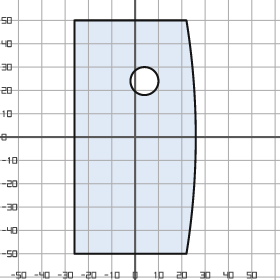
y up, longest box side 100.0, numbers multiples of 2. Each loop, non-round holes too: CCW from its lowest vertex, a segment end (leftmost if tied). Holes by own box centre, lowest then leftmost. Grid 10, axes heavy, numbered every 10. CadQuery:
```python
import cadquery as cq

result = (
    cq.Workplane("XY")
    .moveTo(-26.0, -50.0)
    .lineTo(22.0, -50.0)
    .threePointArc((26.0, 0.0), (22.0, 50.0))
    .lineTo(-26.0, 50.0)
    .close()
    .moveTo(4.0, 24.0)
    .circle(6.0)
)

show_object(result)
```